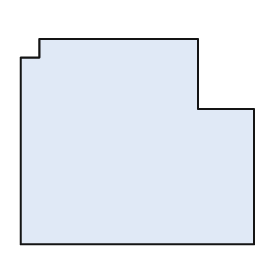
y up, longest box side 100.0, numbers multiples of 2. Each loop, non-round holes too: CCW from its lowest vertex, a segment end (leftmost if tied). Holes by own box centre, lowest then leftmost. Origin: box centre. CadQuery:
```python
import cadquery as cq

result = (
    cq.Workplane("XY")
    .moveTo(-50.0, -44.0)
    .lineTo(50.0, -44.0)
    .lineTo(50.0, 14.0)
    .lineTo(26.0, 14.0)
    .lineTo(26.0, 44.0)
    .lineTo(-42.0, 44.0)
    .lineTo(-42.0, 36.0)
    .lineTo(-50.0, 36.0)
    .close()
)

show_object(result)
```